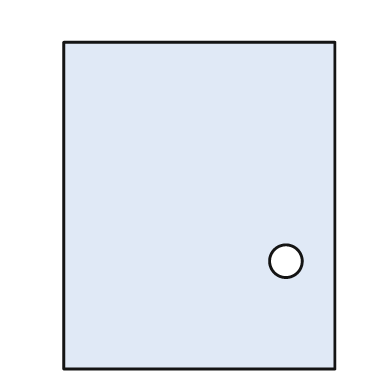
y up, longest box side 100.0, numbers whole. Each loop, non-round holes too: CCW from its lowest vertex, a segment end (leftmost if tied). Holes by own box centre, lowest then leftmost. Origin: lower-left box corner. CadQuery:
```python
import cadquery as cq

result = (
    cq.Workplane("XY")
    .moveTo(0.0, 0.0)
    .lineTo(83.0, 0.0)
    .lineTo(83.0, 100.0)
    .lineTo(0.0, 100.0)
    .close()
    .moveTo(68.0, 33.0)
    .circle(5.0)
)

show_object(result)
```